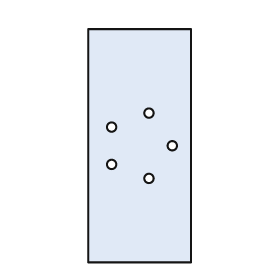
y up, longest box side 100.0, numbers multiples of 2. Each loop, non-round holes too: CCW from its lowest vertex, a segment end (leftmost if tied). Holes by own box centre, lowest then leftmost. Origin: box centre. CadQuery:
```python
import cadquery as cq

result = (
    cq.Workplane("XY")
    .moveTo(-22.0, -50.0)
    .lineTo(22.0, -50.0)
    .lineTo(22.0, 50.0)
    .lineTo(-22.0, 50.0)
    .close()
    .moveTo(4.0, -14.0)
    .circle(2.0)
    .moveTo(-12.0, -8.0)
    .circle(2.0)
    .moveTo(14.0, 0.0)
    .circle(2.0)
    .moveTo(-12.0, 8.0)
    .circle(2.0)
    .moveTo(4.0, 14.0)
    .circle(2.0)
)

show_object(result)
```